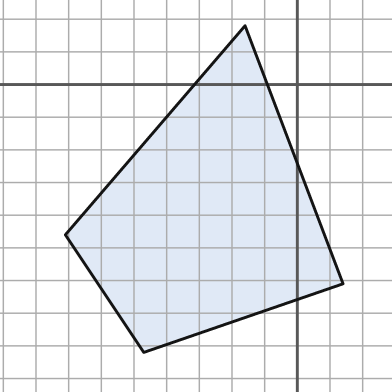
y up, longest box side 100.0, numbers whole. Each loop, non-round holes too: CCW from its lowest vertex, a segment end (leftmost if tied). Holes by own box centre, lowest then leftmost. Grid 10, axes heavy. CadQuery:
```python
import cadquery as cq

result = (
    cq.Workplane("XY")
    .moveTo(-47.0, -82.0)
    .lineTo(14.0, -61.0)
    .lineTo(-16.0, 18.0)
    .lineTo(-71.0, -46.0)
    .close()
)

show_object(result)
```